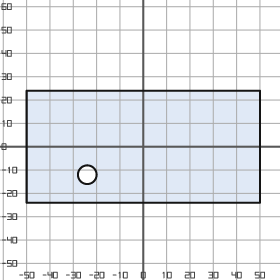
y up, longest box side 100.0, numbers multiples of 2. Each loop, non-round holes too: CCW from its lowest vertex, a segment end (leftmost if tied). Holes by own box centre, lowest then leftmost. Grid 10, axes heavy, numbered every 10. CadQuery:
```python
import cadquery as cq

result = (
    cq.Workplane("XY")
    .moveTo(-50.0, -24.0)
    .lineTo(50.0, -24.0)
    .lineTo(50.0, 24.0)
    .lineTo(-50.0, 24.0)
    .close()
    .moveTo(-24.0, -12.0)
    .circle(4.0)
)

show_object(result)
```